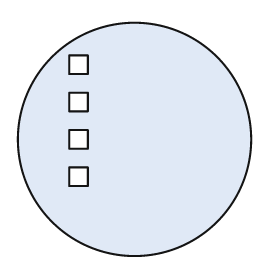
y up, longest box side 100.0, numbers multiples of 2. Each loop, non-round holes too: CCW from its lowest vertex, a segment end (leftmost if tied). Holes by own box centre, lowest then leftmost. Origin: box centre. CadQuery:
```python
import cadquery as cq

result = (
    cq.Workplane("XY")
    .moveTo(0.0, 0.0)
    .circle(50.0)
    .moveTo(-28.0, -20.0)
    .lineTo(-20.0, -20.0)
    .lineTo(-20.0, -12.0)
    .lineTo(-28.0, -12.0)
    .close()
    .moveTo(-28.0, -4.0)
    .lineTo(-20.0, -4.0)
    .lineTo(-20.0, 4.0)
    .lineTo(-28.0, 4.0)
    .close()
    .moveTo(-28.0, 12.0)
    .lineTo(-20.0, 12.0)
    .lineTo(-20.0, 20.0)
    .lineTo(-28.0, 20.0)
    .close()
    .moveTo(-28.0, 28.0)
    .lineTo(-20.0, 28.0)
    .lineTo(-20.0, 36.0)
    .lineTo(-28.0, 36.0)
    .close()
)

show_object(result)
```